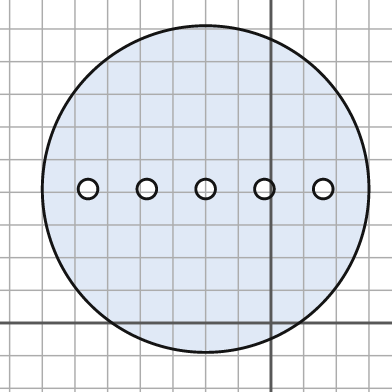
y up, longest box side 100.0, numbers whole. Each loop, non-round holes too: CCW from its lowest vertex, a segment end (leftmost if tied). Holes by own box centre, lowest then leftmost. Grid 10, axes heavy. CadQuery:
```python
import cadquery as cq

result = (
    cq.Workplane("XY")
    .moveTo(-20.0, 41.0)
    .circle(50.0)
    .moveTo(-56.0, 41.0)
    .circle(3.0)
    .moveTo(-38.0, 41.0)
    .circle(3.0)
    .moveTo(-20.0, 41.0)
    .circle(3.0)
    .moveTo(-2.0, 41.0)
    .circle(3.0)
    .moveTo(16.0, 41.0)
    .circle(3.0)
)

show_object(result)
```